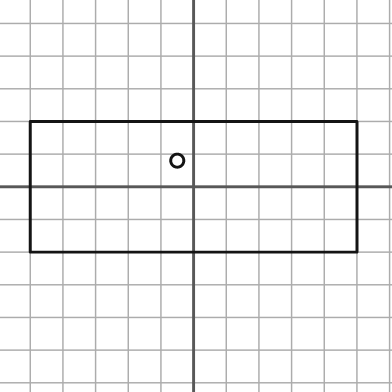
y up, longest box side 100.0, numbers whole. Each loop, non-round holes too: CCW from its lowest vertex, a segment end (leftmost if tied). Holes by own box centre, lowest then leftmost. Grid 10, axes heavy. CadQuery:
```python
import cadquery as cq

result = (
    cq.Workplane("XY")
    .moveTo(-50.0, -20.0)
    .lineTo(50.0, -20.0)
    .lineTo(50.0, 20.0)
    .lineTo(-50.0, 20.0)
    .close()
    .moveTo(-5.0, 8.0)
    .circle(2.0)
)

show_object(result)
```